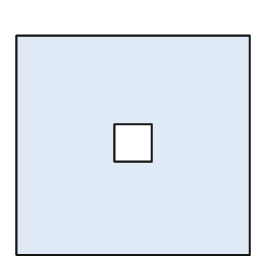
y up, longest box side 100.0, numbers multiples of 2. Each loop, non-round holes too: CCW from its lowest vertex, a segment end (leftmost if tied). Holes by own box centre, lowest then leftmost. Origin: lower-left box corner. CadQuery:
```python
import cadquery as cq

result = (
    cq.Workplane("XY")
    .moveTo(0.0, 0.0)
    .lineTo(100.0, 0.0)
    .lineTo(100.0, 94.0)
    .lineTo(0.0, 94.0)
    .close()
    .moveTo(42.0, 40.0)
    .lineTo(58.0, 40.0)
    .lineTo(58.0, 56.0)
    .lineTo(42.0, 56.0)
    .close()
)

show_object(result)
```